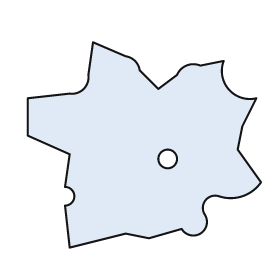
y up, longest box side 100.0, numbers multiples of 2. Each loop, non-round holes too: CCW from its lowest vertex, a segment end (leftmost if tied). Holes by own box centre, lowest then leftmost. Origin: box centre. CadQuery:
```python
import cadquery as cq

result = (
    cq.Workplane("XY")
    .moveTo(-32.0, -44.0)
    .lineTo(-8.0, -38.0)
    .lineTo(2.0, -40.0)
    .lineTo(16.0, -36.0)
    .threePointArc((24.0, -38.0), (26.0, -30.0))
    .threePointArc((26.0, -24.0), (32.0, -22.0))
    .threePointArc((42.0, -22.0), (50.0, -16.0))
    .lineTo(40.0, -2.0)
    .lineTo(42.0, 8.0)
    .lineTo(48.0, 20.0)
    .threePointArc((36.0, 24.0), (34.0, 36.0))
    .lineTo(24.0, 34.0)
    .threePointArc((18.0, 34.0), (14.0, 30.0))
    .lineTo(6.0, 24.0)
    .lineTo(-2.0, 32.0)
    .threePointArc((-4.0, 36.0), (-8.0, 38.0))
    .lineTo(-22.0, 44.0)
    .lineTo(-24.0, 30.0)
    .threePointArc((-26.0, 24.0), (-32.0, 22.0))
    .lineTo(-50.0, 20.0)
    .lineTo(-50.0, 4.0)
    .lineTo(-32.0, -4.0)
    .lineTo(-34.0, -18.0)
    .threePointArc((-30.0, -22.0), (-34.0, -26.0))
    .close()
    .moveTo(10.0, -6.0)
    .circle(4.0)
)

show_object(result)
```